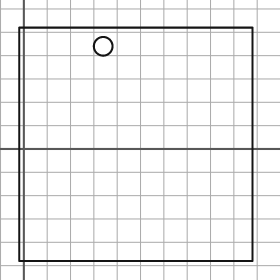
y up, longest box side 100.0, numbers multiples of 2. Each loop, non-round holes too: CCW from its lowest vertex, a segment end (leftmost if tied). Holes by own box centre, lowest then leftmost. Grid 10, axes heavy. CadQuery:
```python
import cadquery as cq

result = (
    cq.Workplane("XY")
    .moveTo(-2.0, -48.0)
    .lineTo(98.0, -48.0)
    .lineTo(98.0, 52.0)
    .lineTo(-2.0, 52.0)
    .close()
    .moveTo(34.0, 44.0)
    .circle(4.0)
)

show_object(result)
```